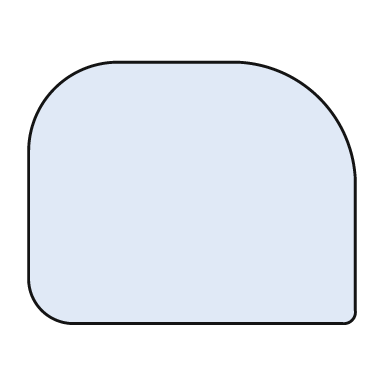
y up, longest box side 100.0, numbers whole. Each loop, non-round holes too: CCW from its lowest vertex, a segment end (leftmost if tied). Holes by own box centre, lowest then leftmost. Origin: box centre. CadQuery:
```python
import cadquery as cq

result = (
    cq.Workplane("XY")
    .moveTo(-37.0, -40.0)
    .lineTo(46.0, -40.0)
    .threePointArc((49.0, -39.0), (50.0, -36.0))
    .lineTo(50.0, 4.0)
    .threePointArc((39.0, 29.0), (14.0, 40.0))
    .lineTo(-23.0, 40.0)
    .threePointArc((-42.0, 32.0), (-50.0, 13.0))
    .lineTo(-50.0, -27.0)
    .threePointArc((-46.0, -36.0), (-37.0, -40.0))
    .close()
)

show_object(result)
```